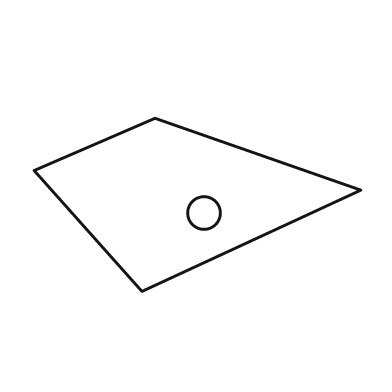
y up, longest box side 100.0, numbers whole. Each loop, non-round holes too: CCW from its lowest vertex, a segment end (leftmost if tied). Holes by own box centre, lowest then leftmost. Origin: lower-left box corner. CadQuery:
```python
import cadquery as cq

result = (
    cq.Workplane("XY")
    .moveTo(33.0, 0.0)
    .lineTo(100.0, 31.0)
    .lineTo(37.0, 53.0)
    .lineTo(0.0, 37.0)
    .close()
    .moveTo(52.0, 24.0)
    .circle(5.0)
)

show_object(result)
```